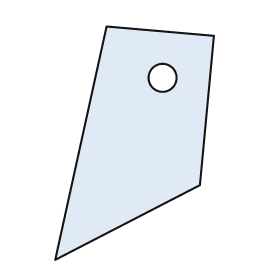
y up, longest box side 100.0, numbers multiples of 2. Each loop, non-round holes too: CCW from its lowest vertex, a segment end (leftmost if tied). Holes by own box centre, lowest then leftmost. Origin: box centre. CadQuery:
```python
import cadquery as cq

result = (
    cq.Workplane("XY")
    .moveTo(-34.0, -50.0)
    .lineTo(28.0, -18.0)
    .lineTo(34.0, 46.0)
    .lineTo(-12.0, 50.0)
    .close()
    .moveTo(12.0, 28.0)
    .circle(6.0)
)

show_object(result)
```